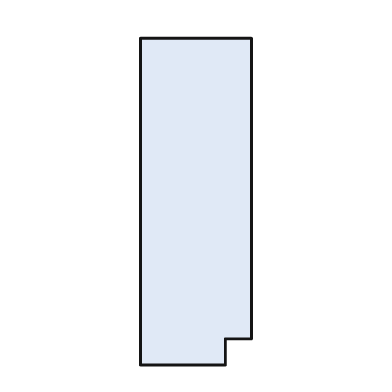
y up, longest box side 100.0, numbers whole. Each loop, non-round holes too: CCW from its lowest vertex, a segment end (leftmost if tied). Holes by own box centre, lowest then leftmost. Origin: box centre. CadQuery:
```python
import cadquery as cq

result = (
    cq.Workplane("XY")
    .moveTo(-17.0, -50.0)
    .lineTo(9.0, -50.0)
    .lineTo(9.0, -42.0)
    .lineTo(17.0, -42.0)
    .lineTo(17.0, 50.0)
    .lineTo(-17.0, 50.0)
    .close()
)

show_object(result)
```